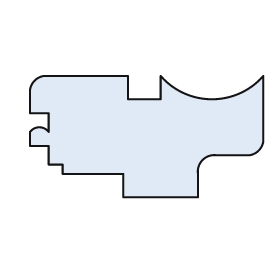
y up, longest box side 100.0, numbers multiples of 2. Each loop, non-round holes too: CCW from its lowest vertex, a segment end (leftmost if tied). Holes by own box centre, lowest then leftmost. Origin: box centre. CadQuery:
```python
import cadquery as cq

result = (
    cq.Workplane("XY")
    .moveTo(-10.0, -26.0)
    .lineTo(22.0, -26.0)
    .lineTo(22.0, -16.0)
    .threePointArc((24.0, -10.0), (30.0, -8.0))
    .lineTo(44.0, -8.0)
    .threePointArc((48.0, -6.0), (50.0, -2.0))
    .lineTo(50.0, 26.0)
    .threePointArc((28.0, 16.0), (6.0, 26.0))
    .lineTo(6.0, 16.0)
    .lineTo(-8.0, 16.0)
    .lineTo(-8.0, 26.0)
    .lineTo(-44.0, 26.0)
    .threePointArc((-48.0, 24.0), (-50.0, 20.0))
    .lineTo(-50.0, 10.0)
    .lineTo(-42.0, 10.0)
    .lineTo(-42.0, 2.0)
    .threePointArc((-46.0, 4.0), (-50.0, 2.0))
    .lineTo(-50.0, -4.0)
    .lineTo(-42.0, -4.0)
    .lineTo(-42.0, -12.0)
    .lineTo(-36.0, -12.0)
    .lineTo(-36.0, -16.0)
    .lineTo(-10.0, -16.0)
    .close()
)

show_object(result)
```